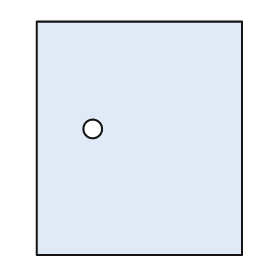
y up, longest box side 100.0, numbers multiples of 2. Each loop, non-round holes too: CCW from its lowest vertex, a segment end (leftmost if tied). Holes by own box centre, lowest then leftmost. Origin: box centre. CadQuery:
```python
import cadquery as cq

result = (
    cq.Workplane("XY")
    .moveTo(-44.0, -50.0)
    .lineTo(44.0, -50.0)
    .lineTo(44.0, 50.0)
    .lineTo(-44.0, 50.0)
    .close()
    .moveTo(-20.0, 4.0)
    .circle(4.0)
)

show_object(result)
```